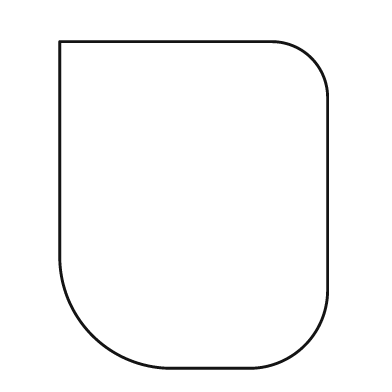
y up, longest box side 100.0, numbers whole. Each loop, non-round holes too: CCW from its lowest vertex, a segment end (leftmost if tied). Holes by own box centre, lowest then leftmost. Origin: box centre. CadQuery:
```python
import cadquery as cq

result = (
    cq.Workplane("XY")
    .moveTo(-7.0, -50.0)
    .lineTo(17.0, -50.0)
    .threePointArc((34.0, -43.0), (41.0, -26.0))
    .lineTo(41.0, 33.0)
    .threePointArc((36.0, 45.0), (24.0, 50.0))
    .lineTo(-41.0, 50.0)
    .lineTo(-41.0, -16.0)
    .threePointArc((-31.0, -40.0), (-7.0, -50.0))
    .close()
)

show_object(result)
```